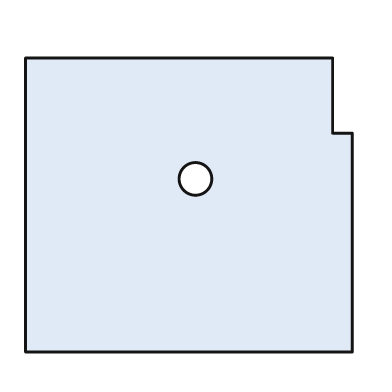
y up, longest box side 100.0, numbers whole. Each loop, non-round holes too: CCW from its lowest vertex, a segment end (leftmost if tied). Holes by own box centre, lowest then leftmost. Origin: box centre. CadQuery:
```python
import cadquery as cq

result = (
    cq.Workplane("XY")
    .moveTo(-50.0, -45.0)
    .lineTo(50.0, -45.0)
    .lineTo(50.0, 22.0)
    .lineTo(44.0, 22.0)
    .lineTo(44.0, 45.0)
    .lineTo(-50.0, 45.0)
    .close()
    .moveTo(2.0, 8.0)
    .circle(5.0)
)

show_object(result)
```